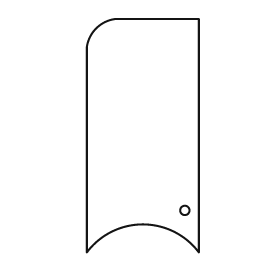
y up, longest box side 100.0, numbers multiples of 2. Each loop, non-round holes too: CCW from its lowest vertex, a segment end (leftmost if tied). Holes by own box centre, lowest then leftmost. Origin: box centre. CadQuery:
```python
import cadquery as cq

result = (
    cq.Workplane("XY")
    .moveTo(-24.0, -50.0)
    .threePointArc((0.0, -38.0), (24.0, -50.0))
    .lineTo(24.0, 50.0)
    .lineTo(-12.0, 50.0)
    .threePointArc((-20.0, 46.0), (-24.0, 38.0))
    .close()
    .moveTo(18.0, -32.0)
    .circle(2.0)
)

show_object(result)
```